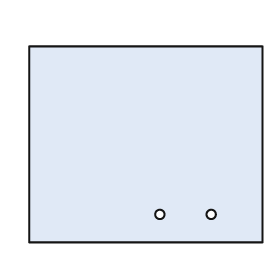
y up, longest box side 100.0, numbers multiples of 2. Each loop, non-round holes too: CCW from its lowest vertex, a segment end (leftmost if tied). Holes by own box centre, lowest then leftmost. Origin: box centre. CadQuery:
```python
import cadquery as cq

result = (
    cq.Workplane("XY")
    .moveTo(-50.0, -42.0)
    .lineTo(50.0, -42.0)
    .lineTo(50.0, 42.0)
    .lineTo(-50.0, 42.0)
    .close()
    .moveTo(6.0, -30.0)
    .circle(2.0)
    .moveTo(28.0, -30.0)
    .circle(2.0)
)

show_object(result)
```